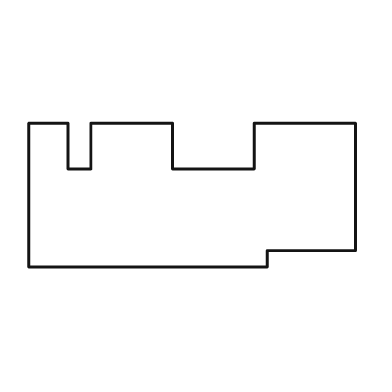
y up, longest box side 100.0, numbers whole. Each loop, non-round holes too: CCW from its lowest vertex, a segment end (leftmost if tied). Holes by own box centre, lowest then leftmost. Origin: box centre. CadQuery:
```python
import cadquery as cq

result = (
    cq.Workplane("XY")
    .moveTo(-50.0, -22.0)
    .lineTo(23.0, -22.0)
    .lineTo(23.0, -17.0)
    .lineTo(50.0, -17.0)
    .lineTo(50.0, 22.0)
    .lineTo(19.0, 22.0)
    .lineTo(19.0, 8.0)
    .lineTo(-6.0, 8.0)
    .lineTo(-6.0, 22.0)
    .lineTo(-31.0, 22.0)
    .lineTo(-31.0, 8.0)
    .lineTo(-38.0, 8.0)
    .lineTo(-38.0, 22.0)
    .lineTo(-50.0, 22.0)
    .close()
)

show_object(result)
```